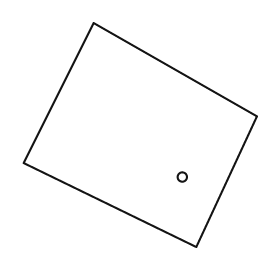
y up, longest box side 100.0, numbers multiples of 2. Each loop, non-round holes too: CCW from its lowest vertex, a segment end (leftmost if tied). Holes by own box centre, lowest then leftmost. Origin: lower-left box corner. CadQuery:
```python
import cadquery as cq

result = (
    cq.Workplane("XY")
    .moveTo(74.0, 0.0)
    .lineTo(100.0, 56.0)
    .lineTo(30.0, 96.0)
    .lineTo(0.0, 36.0)
    .close()
    .moveTo(68.0, 30.0)
    .circle(2.0)
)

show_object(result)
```